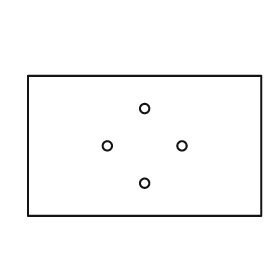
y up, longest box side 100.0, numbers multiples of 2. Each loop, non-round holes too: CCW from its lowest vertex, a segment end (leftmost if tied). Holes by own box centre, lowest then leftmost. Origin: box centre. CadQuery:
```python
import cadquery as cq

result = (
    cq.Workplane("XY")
    .moveTo(-50.0, -30.0)
    .lineTo(50.0, -30.0)
    .lineTo(50.0, 30.0)
    .lineTo(-50.0, 30.0)
    .close()
    .moveTo(0.0, -16.0)
    .circle(2.0)
    .moveTo(-16.0, 0.0)
    .circle(2.0)
    .moveTo(16.0, 0.0)
    .circle(2.0)
    .moveTo(0.0, 16.0)
    .circle(2.0)
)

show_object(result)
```